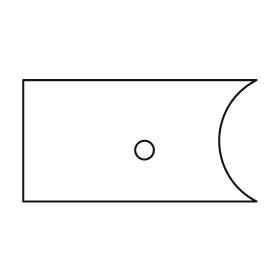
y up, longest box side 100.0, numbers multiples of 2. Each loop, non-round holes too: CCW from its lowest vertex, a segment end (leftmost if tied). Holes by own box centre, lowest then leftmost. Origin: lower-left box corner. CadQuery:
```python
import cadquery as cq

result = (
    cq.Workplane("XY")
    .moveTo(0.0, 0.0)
    .lineTo(100.0, 0.0)
    .threePointArc((84.0, 26.0), (100.0, 52.0))
    .lineTo(0.0, 52.0)
    .close()
    .moveTo(52.0, 22.0)
    .circle(4.0)
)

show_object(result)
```